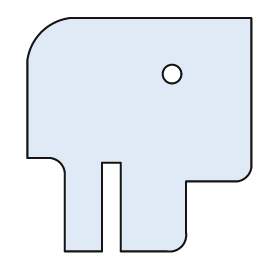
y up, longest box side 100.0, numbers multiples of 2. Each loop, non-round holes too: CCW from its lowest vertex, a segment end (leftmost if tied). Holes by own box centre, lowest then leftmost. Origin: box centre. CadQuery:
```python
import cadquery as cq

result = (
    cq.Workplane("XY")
    .moveTo(-32.0, -50.0)
    .lineTo(-16.0, -50.0)
    .lineTo(-16.0, -12.0)
    .lineTo(-8.0, -12.0)
    .lineTo(-8.0, -50.0)
    .lineTo(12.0, -50.0)
    .threePointArc((18.0, -48.0), (20.0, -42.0))
    .lineTo(20.0, -20.0)
    .lineTo(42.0, -20.0)
    .threePointArc((46.0, -18.0), (48.0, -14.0))
    .lineTo(48.0, 50.0)
    .lineTo(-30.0, 50.0)
    .threePointArc((-42.0, 44.0), (-48.0, 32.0))
    .lineTo(-48.0, -10.0)
    .lineTo(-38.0, -10.0)
    .threePointArc((-34.0, -12.0), (-32.0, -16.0))
    .close()
    .moveTo(14.0, 26.0)
    .circle(4.0)
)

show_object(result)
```